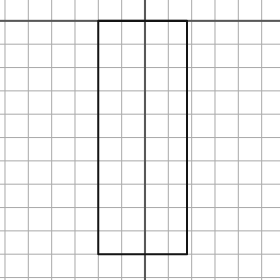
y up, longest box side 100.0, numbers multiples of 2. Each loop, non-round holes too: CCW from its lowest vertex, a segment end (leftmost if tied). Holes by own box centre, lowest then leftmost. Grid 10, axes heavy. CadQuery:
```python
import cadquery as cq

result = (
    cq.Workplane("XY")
    .moveTo(-20.0, -100.0)
    .lineTo(18.0, -100.0)
    .lineTo(18.0, 0.0)
    .lineTo(-20.0, 0.0)
    .close()
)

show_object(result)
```